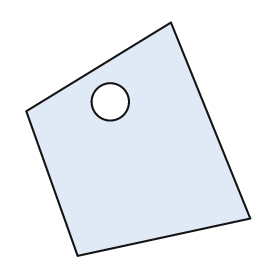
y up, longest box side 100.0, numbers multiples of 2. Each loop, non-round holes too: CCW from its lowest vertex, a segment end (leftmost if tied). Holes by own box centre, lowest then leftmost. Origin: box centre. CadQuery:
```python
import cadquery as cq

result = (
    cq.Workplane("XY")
    .moveTo(-26.0, -50.0)
    .lineTo(48.0, -34.0)
    .lineTo(14.0, 50.0)
    .lineTo(-48.0, 12.0)
    .close()
    .moveTo(-12.0, 16.0)
    .circle(8.0)
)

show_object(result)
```